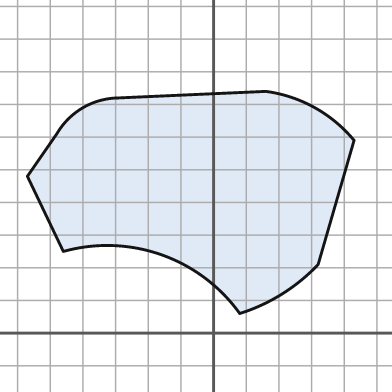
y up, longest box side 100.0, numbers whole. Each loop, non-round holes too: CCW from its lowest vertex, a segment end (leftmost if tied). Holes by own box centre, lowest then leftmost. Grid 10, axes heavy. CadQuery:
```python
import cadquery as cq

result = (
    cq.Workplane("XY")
    .moveTo(8.0, 6.0)
    .threePointArc((21.0, 12.0), (32.0, 21.0))
    .lineTo(43.0, 59.0)
    .threePointArc((31.0, 69.0), (16.0, 74.0))
    .lineTo(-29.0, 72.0)
    .threePointArc((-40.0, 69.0), (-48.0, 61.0))
    .lineTo(-57.0, 48.0)
    .lineTo(-46.0, 25.0)
    .threePointArc((-16.0, 24.0), (8.0, 6.0))
    .close()
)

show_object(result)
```